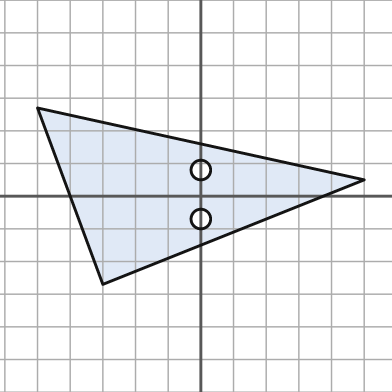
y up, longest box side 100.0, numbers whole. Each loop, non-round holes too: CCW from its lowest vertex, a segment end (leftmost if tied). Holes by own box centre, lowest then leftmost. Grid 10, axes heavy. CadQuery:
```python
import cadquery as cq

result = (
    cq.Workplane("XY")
    .moveTo(-30.0, -27.0)
    .lineTo(50.0, 5.0)
    .lineTo(-50.0, 27.0)
    .close()
    .moveTo(0.0, -7.0)
    .circle(3.0)
    .moveTo(0.0, 8.0)
    .circle(3.0)
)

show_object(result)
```